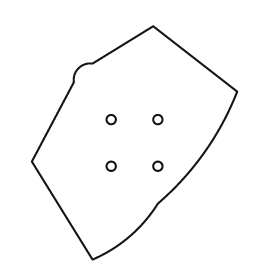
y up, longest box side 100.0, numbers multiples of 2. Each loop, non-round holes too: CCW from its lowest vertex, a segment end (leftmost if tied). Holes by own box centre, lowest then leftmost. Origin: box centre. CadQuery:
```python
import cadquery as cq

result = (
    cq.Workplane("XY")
    .moveTo(-18.0, -50.0)
    .threePointArc((-2.0, -40.0), (10.0, -26.0))
    .threePointArc((30.0, -4.0), (44.0, 22.0))
    .lineTo(8.0, 50.0)
    .lineTo(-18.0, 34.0)
    .threePointArc((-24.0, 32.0), (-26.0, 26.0))
    .lineTo(-44.0, -8.0)
    .close()
    .moveTo(-10.0, -10.0)
    .circle(2.0)
    .moveTo(10.0, -10.0)
    .circle(2.0)
    .moveTo(-10.0, 10.0)
    .circle(2.0)
    .moveTo(10.0, 10.0)
    .circle(2.0)
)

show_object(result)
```